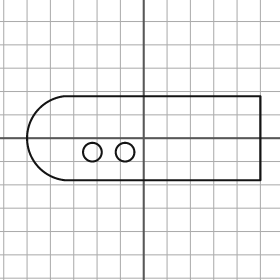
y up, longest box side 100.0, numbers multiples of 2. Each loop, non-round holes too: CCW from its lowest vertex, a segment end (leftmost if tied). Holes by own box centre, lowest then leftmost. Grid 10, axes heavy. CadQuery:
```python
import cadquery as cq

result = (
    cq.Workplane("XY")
    .moveTo(-34.0, -18.0)
    .lineTo(50.0, -18.0)
    .lineTo(50.0, 18.0)
    .lineTo(-34.0, 18.0)
    .threePointArc((-50.0, 0.0), (-34.0, -18.0))
    .close()
    .moveTo(-22.0, -6.0)
    .circle(4.0)
    .moveTo(-8.0, -6.0)
    .circle(4.0)
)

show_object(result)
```